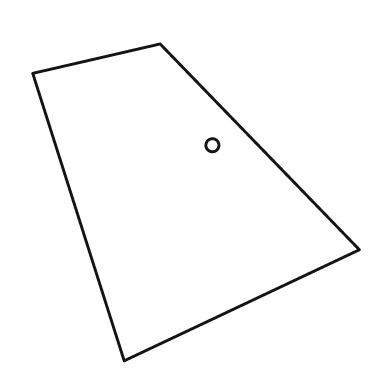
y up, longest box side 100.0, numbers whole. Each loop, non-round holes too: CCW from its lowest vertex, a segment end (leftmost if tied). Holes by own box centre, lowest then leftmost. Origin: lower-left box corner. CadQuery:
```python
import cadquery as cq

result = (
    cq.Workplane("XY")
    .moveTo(28.0, 0.0)
    .lineTo(100.0, 34.0)
    .lineTo(39.0, 97.0)
    .lineTo(0.0, 88.0)
    .close()
    .moveTo(55.0, 66.0)
    .circle(2.0)
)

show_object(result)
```